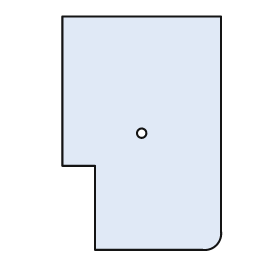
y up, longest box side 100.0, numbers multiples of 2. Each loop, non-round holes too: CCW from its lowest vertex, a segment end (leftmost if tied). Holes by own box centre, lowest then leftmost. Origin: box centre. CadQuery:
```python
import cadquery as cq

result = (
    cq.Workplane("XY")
    .moveTo(-20.0, -50.0)
    .lineTo(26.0, -50.0)
    .threePointArc((32.0, -48.0), (34.0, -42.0))
    .lineTo(34.0, 50.0)
    .lineTo(-34.0, 50.0)
    .lineTo(-34.0, -14.0)
    .lineTo(-20.0, -14.0)
    .close()
    .moveTo(0.0, 0.0)
    .circle(2.0)
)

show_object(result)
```